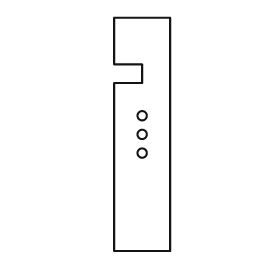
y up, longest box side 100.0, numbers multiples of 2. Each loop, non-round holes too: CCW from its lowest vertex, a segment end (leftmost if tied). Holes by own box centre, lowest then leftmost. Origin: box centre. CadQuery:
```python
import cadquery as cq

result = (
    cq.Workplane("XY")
    .moveTo(-12.0, -50.0)
    .lineTo(12.0, -50.0)
    .lineTo(12.0, 50.0)
    .lineTo(-12.0, 50.0)
    .lineTo(-12.0, 30.0)
    .lineTo(0.0, 30.0)
    .lineTo(0.0, 22.0)
    .lineTo(-12.0, 22.0)
    .close()
    .moveTo(0.0, -8.0)
    .circle(2.0)
    .moveTo(0.0, 0.0)
    .circle(2.0)
    .moveTo(0.0, 8.0)
    .circle(2.0)
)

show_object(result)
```